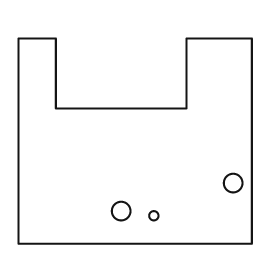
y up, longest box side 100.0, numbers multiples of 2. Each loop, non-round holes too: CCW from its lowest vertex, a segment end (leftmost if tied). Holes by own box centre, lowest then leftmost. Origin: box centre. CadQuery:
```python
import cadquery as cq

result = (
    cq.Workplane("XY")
    .moveTo(-50.0, -44.0)
    .lineTo(50.0, -44.0)
    .lineTo(50.0, 44.0)
    .lineTo(22.0, 44.0)
    .lineTo(22.0, 14.0)
    .lineTo(-34.0, 14.0)
    .lineTo(-34.0, 44.0)
    .lineTo(-50.0, 44.0)
    .close()
    .moveTo(8.0, -32.0)
    .circle(2.0)
    .moveTo(-6.0, -30.0)
    .circle(4.0)
    .moveTo(42.0, -18.0)
    .circle(4.0)
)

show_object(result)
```